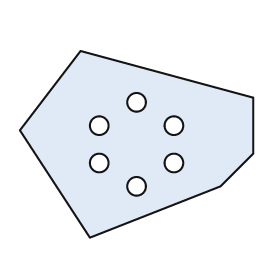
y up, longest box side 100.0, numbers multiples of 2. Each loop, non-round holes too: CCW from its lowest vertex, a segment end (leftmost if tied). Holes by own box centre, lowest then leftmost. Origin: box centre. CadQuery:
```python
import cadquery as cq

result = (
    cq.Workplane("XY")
    .moveTo(-20.0, -40.0)
    .lineTo(36.0, -18.0)
    .lineTo(50.0, -4.0)
    .lineTo(50.0, 20.0)
    .lineTo(-24.0, 40.0)
    .lineTo(-50.0, 6.0)
    .close()
    .moveTo(0.0, -18.0)
    .circle(4.0)
    .moveTo(-16.0, -8.0)
    .circle(4.0)
    .moveTo(16.0, -8.0)
    .circle(4.0)
    .moveTo(-16.0, 8.0)
    .circle(4.0)
    .moveTo(16.0, 8.0)
    .circle(4.0)
    .moveTo(0.0, 18.0)
    .circle(4.0)
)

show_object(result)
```